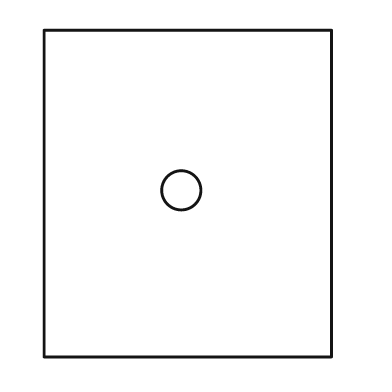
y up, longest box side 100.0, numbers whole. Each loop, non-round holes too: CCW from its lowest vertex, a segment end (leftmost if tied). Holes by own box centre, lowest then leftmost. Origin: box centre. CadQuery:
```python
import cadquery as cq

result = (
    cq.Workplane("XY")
    .moveTo(-44.0, -50.0)
    .lineTo(44.0, -50.0)
    .lineTo(44.0, 50.0)
    .lineTo(-44.0, 50.0)
    .close()
    .moveTo(-2.0, 1.0)
    .circle(6.0)
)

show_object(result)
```